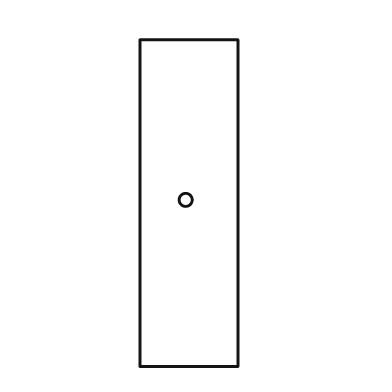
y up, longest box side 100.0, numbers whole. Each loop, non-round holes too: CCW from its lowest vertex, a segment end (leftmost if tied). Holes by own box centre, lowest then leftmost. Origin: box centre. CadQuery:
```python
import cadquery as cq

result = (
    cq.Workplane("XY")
    .moveTo(-15.0, -50.0)
    .lineTo(15.0, -50.0)
    .lineTo(15.0, 50.0)
    .lineTo(-15.0, 50.0)
    .close()
    .moveTo(-1.0, 1.0)
    .circle(2.0)
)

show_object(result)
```